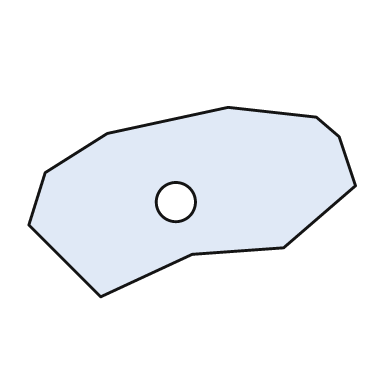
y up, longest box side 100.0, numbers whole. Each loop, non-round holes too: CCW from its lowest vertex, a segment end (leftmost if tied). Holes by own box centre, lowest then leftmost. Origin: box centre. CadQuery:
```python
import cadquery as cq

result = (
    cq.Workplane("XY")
    .moveTo(-28.0, -29.0)
    .lineTo(0.0, -16.0)
    .lineTo(28.0, -14.0)
    .lineTo(50.0, 5.0)
    .lineTo(45.0, 20.0)
    .lineTo(38.0, 26.0)
    .lineTo(11.0, 29.0)
    .lineTo(-26.0, 21.0)
    .lineTo(-45.0, 9.0)
    .lineTo(-50.0, -7.0)
    .close()
    .moveTo(-5.0, 0.0)
    .circle(6.0)
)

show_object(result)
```